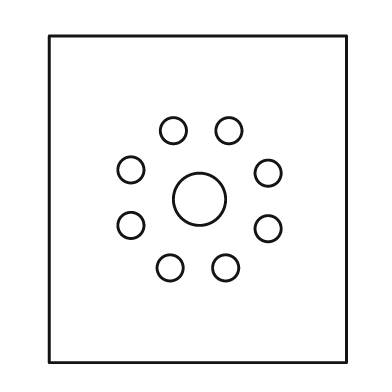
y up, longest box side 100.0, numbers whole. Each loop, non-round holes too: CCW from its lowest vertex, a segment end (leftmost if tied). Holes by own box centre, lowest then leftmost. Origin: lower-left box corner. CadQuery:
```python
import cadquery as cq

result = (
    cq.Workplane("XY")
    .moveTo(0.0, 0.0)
    .lineTo(91.0, 0.0)
    .lineTo(91.0, 100.0)
    .lineTo(0.0, 100.0)
    .close()
    .moveTo(37.0, 29.0)
    .circle(4.0)
    .moveTo(54.0, 29.0)
    .circle(4.0)
    .moveTo(67.0, 41.0)
    .circle(4.0)
    .moveTo(25.0, 42.0)
    .circle(4.0)
    .moveTo(46.0, 50.0)
    .circle(8.0)
    .moveTo(67.0, 58.0)
    .circle(4.0)
    .moveTo(25.0, 59.0)
    .circle(4.0)
    .moveTo(38.0, 71.0)
    .circle(4.0)
    .moveTo(55.0, 71.0)
    .circle(4.0)
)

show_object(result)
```